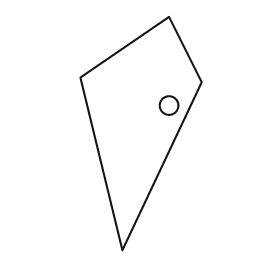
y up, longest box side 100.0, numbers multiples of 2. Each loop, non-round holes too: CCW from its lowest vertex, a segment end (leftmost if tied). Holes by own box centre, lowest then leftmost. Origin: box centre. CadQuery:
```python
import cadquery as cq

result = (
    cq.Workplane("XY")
    .moveTo(-8.0, -50.0)
    .lineTo(26.0, 22.0)
    .lineTo(12.0, 50.0)
    .lineTo(-26.0, 24.0)
    .close()
    .moveTo(12.0, 12.0)
    .circle(4.0)
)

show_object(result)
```